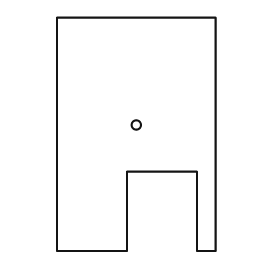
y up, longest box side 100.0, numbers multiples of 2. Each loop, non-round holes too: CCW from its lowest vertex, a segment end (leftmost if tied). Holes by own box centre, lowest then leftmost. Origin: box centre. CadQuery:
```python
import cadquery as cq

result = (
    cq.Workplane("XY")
    .moveTo(-34.0, -50.0)
    .lineTo(-4.0, -50.0)
    .lineTo(-4.0, -16.0)
    .lineTo(26.0, -16.0)
    .lineTo(26.0, -50.0)
    .lineTo(34.0, -50.0)
    .lineTo(34.0, 50.0)
    .lineTo(-34.0, 50.0)
    .close()
    .moveTo(0.0, 4.0)
    .circle(2.0)
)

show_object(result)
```